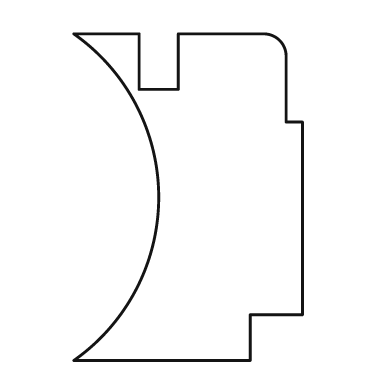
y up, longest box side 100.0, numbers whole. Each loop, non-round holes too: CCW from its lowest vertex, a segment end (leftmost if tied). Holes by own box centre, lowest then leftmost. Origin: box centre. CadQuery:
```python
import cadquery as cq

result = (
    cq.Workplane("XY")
    .moveTo(-35.0, -50.0)
    .lineTo(19.0, -50.0)
    .lineTo(19.0, -36.0)
    .lineTo(35.0, -36.0)
    .lineTo(35.0, 23.0)
    .lineTo(30.0, 23.0)
    .lineTo(30.0, 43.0)
    .threePointArc((28.0, 48.0), (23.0, 50.0))
    .lineTo(-3.0, 50.0)
    .lineTo(-3.0, 33.0)
    .lineTo(-15.0, 33.0)
    .lineTo(-15.0, 50.0)
    .lineTo(-35.0, 50.0)
    .threePointArc((-9.0, 0.0), (-35.0, -50.0))
    .close()
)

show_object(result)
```